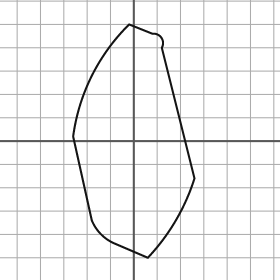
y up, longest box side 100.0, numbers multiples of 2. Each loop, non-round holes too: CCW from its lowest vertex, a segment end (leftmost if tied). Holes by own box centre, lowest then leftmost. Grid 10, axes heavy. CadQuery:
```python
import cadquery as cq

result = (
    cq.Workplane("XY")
    .moveTo(6.0, -50.0)
    .threePointArc((18.0, -34.0), (26.0, -16.0))
    .lineTo(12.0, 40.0)
    .threePointArc((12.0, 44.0), (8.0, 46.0))
    .lineTo(-2.0, 50.0)
    .threePointArc((-18.0, 28.0), (-26.0, 2.0))
    .lineTo(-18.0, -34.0)
    .threePointArc((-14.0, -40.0), (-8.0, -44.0))
    .close()
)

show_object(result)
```